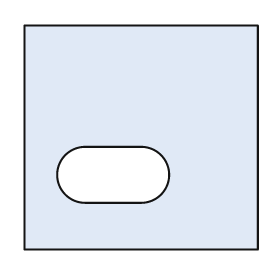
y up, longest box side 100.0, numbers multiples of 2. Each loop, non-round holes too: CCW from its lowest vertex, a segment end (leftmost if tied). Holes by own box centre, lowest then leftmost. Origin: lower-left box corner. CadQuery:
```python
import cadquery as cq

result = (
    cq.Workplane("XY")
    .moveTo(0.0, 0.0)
    .lineTo(100.0, 0.0)
    .lineTo(100.0, 96.0)
    .lineTo(0.0, 96.0)
    .close()
    .moveTo(26.0, 20.0)
    .lineTo(50.0, 20.0)
    .threePointArc((62.0, 32.0), (50.0, 44.0))
    .lineTo(26.0, 44.0)
    .threePointArc((14.0, 32.0), (26.0, 20.0))
    .close()
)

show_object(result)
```